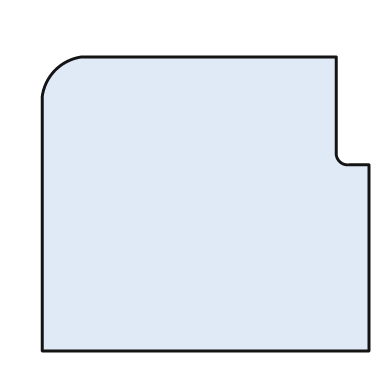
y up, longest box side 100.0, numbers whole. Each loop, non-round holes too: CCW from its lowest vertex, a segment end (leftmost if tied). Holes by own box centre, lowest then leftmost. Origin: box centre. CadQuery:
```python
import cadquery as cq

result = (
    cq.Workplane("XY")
    .moveTo(-50.0, -45.0)
    .lineTo(50.0, -45.0)
    .lineTo(50.0, 12.0)
    .lineTo(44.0, 12.0)
    .threePointArc((41.0, 13.0), (40.0, 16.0))
    .lineTo(40.0, 45.0)
    .lineTo(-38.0, 45.0)
    .threePointArc((-46.0, 41.0), (-50.0, 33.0))
    .close()
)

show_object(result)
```